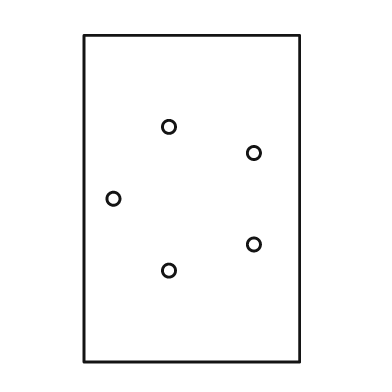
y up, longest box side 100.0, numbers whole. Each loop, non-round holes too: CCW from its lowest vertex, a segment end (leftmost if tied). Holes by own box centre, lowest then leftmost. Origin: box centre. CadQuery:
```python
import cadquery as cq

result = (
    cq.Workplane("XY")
    .moveTo(-33.0, -50.0)
    .lineTo(33.0, -50.0)
    .lineTo(33.0, 50.0)
    .lineTo(-33.0, 50.0)
    .close()
    .moveTo(-7.0, -22.0)
    .circle(2.0)
    .moveTo(19.0, -14.0)
    .circle(2.0)
    .moveTo(-24.0, 0.0)
    .circle(2.0)
    .moveTo(19.0, 14.0)
    .circle(2.0)
    .moveTo(-7.0, 22.0)
    .circle(2.0)
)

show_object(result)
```